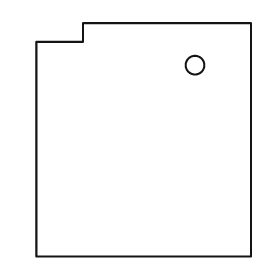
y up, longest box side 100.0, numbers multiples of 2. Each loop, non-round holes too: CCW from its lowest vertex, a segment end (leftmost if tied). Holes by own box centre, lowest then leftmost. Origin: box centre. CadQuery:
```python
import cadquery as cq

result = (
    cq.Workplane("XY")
    .moveTo(-46.0, -50.0)
    .lineTo(46.0, -50.0)
    .lineTo(46.0, 50.0)
    .lineTo(-26.0, 50.0)
    .lineTo(-26.0, 42.0)
    .lineTo(-46.0, 42.0)
    .close()
    .moveTo(22.0, 32.0)
    .circle(4.0)
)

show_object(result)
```